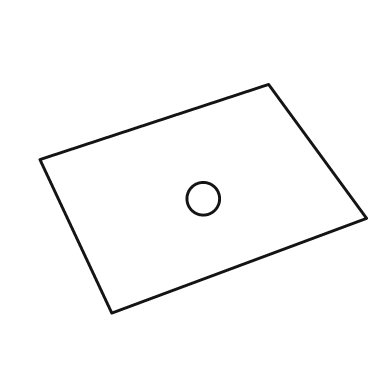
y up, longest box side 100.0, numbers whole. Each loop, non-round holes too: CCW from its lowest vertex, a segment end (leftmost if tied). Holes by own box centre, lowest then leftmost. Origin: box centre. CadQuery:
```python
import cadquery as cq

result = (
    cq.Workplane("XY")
    .moveTo(-28.0, -35.0)
    .lineTo(50.0, -6.0)
    .lineTo(20.0, 35.0)
    .lineTo(-50.0, 12.0)
    .close()
    .moveTo(0.0, 0.0)
    .circle(5.0)
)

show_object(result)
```